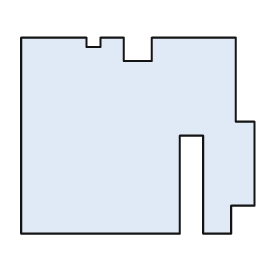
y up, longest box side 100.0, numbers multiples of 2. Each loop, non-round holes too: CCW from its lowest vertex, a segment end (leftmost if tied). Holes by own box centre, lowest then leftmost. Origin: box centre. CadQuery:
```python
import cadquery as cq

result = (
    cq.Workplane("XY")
    .moveTo(-50.0, -42.0)
    .lineTo(18.0, -42.0)
    .lineTo(18.0, 0.0)
    .lineTo(28.0, 0.0)
    .lineTo(28.0, -42.0)
    .lineTo(40.0, -42.0)
    .lineTo(40.0, -30.0)
    .lineTo(50.0, -30.0)
    .lineTo(50.0, 6.0)
    .lineTo(42.0, 6.0)
    .lineTo(42.0, 42.0)
    .lineTo(6.0, 42.0)
    .lineTo(6.0, 32.0)
    .lineTo(-6.0, 32.0)
    .lineTo(-6.0, 42.0)
    .lineTo(-16.0, 42.0)
    .lineTo(-16.0, 38.0)
    .lineTo(-22.0, 38.0)
    .lineTo(-22.0, 42.0)
    .lineTo(-50.0, 42.0)
    .close()
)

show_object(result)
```